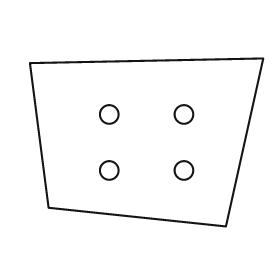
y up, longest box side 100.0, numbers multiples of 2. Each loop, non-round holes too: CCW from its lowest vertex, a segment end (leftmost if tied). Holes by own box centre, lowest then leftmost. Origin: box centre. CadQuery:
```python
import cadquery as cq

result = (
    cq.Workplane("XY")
    .moveTo(34.0, -36.0)
    .lineTo(50.0, 36.0)
    .lineTo(-50.0, 34.0)
    .lineTo(-42.0, -28.0)
    .close()
    .moveTo(-16.0, -12.0)
    .circle(4.0)
    .moveTo(16.0, -12.0)
    .circle(4.0)
    .moveTo(-16.0, 12.0)
    .circle(4.0)
    .moveTo(16.0, 12.0)
    .circle(4.0)
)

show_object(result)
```